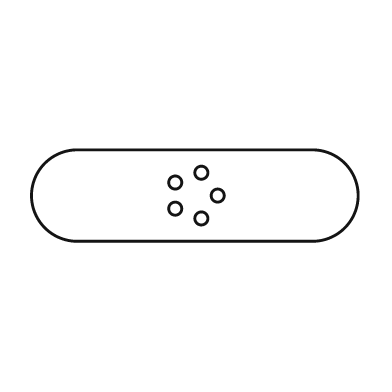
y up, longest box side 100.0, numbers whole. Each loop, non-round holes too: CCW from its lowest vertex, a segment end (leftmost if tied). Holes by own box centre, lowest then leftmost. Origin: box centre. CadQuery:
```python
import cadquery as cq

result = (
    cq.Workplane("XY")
    .moveTo(-36.0, -14.0)
    .lineTo(36.0, -14.0)
    .threePointArc((50.0, 0.0), (36.0, 14.0))
    .lineTo(-36.0, 14.0)
    .threePointArc((-50.0, 0.0), (-36.0, -14.0))
    .close()
    .moveTo(2.0, -7.0)
    .circle(2.0)
    .moveTo(-6.0, -4.0)
    .circle(2.0)
    .moveTo(7.0, 0.0)
    .circle(2.0)
    .moveTo(-6.0, 4.0)
    .circle(2.0)
    .moveTo(2.0, 7.0)
    .circle(2.0)
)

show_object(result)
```